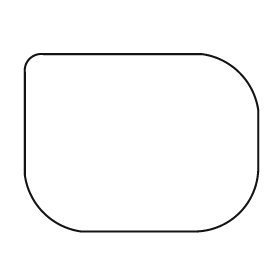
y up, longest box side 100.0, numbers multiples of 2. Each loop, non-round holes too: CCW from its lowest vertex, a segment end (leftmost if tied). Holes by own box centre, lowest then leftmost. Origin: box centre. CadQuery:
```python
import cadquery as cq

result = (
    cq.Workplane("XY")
    .moveTo(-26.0, -38.0)
    .lineTo(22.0, -38.0)
    .threePointArc((42.0, -30.0), (50.0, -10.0))
    .lineTo(50.0, 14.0)
    .threePointArc((42.0, 30.0), (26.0, 38.0))
    .lineTo(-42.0, 38.0)
    .threePointArc((-48.0, 36.0), (-50.0, 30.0))
    .lineTo(-50.0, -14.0)
    .threePointArc((-42.0, -30.0), (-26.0, -38.0))
    .close()
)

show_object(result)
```